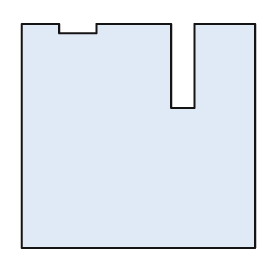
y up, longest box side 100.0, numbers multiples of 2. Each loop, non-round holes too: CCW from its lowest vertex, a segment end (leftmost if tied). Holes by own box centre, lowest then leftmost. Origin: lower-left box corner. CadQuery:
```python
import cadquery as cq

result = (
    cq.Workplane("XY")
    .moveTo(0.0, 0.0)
    .lineTo(100.0, 0.0)
    .lineTo(100.0, 96.0)
    .lineTo(74.0, 96.0)
    .lineTo(74.0, 60.0)
    .lineTo(64.0, 60.0)
    .lineTo(64.0, 96.0)
    .lineTo(32.0, 96.0)
    .lineTo(32.0, 92.0)
    .lineTo(16.0, 92.0)
    .lineTo(16.0, 96.0)
    .lineTo(0.0, 96.0)
    .close()
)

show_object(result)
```